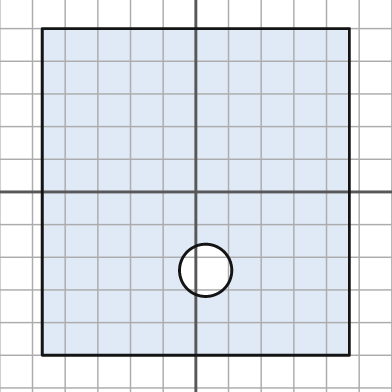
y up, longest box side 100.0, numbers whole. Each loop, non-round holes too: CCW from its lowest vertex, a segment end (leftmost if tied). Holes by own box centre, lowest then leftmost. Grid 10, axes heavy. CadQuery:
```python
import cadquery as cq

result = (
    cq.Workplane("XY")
    .moveTo(-47.0, -50.0)
    .lineTo(47.0, -50.0)
    .lineTo(47.0, 50.0)
    .lineTo(-47.0, 50.0)
    .close()
    .moveTo(3.0, -24.0)
    .circle(8.0)
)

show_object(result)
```